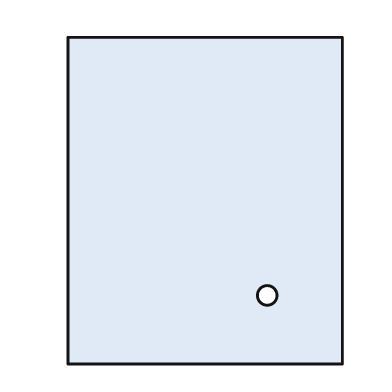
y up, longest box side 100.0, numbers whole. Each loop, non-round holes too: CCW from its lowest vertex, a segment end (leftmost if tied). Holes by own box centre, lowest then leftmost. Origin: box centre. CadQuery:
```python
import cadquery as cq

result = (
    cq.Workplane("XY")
    .moveTo(-42.0, -50.0)
    .lineTo(42.0, -50.0)
    .lineTo(42.0, 50.0)
    .lineTo(-42.0, 50.0)
    .close()
    .moveTo(19.0, -29.0)
    .circle(3.0)
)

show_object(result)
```